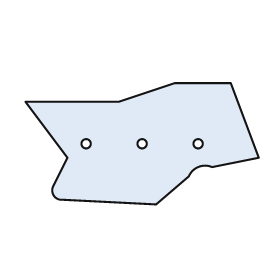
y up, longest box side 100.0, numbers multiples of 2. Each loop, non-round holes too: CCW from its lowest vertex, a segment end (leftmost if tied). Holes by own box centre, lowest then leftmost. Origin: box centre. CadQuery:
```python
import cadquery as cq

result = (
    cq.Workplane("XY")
    .moveTo(6.0, -26.0)
    .lineTo(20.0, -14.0)
    .threePointArc((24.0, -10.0), (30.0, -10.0))
    .lineTo(50.0, -6.0)
    .lineTo(38.0, 26.0)
    .lineTo(14.0, 26.0)
    .lineTo(-10.0, 18.0)
    .lineTo(-50.0, 18.0)
    .lineTo(-32.0, -6.0)
    .lineTo(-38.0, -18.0)
    .threePointArc((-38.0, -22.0), (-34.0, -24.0))
    .close()
    .moveTo(-24.0, 0.0)
    .circle(2.0)
    .moveTo(0.0, 0.0)
    .circle(2.0)
    .moveTo(24.0, 0.0)
    .circle(2.0)
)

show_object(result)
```